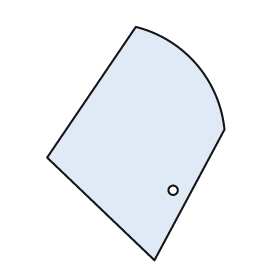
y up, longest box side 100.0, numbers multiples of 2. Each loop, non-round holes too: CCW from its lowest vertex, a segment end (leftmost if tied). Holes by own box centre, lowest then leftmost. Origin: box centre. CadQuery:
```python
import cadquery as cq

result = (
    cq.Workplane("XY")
    .moveTo(8.0, -50.0)
    .lineTo(38.0, 6.0)
    .threePointArc((26.0, 34.0), (0.0, 50.0))
    .lineTo(-38.0, -6.0)
    .close()
    .moveTo(16.0, -20.0)
    .circle(2.0)
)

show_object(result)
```